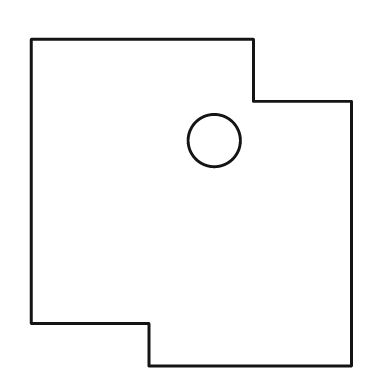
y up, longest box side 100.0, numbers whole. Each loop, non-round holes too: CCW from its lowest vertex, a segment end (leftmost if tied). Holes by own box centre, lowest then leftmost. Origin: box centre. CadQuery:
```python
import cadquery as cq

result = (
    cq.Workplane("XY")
    .moveTo(-13.0, -50.0)
    .lineTo(49.0, -50.0)
    .lineTo(49.0, 31.0)
    .lineTo(19.0, 31.0)
    .lineTo(19.0, 50.0)
    .lineTo(-49.0, 50.0)
    .lineTo(-49.0, -37.0)
    .lineTo(-13.0, -37.0)
    .close()
    .moveTo(7.0, 19.0)
    .circle(8.0)
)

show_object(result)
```